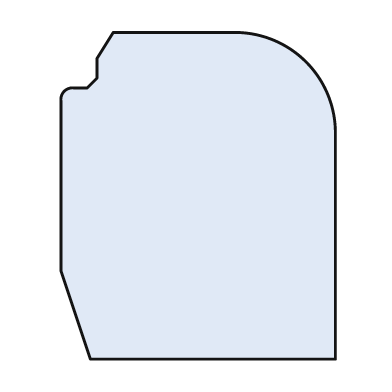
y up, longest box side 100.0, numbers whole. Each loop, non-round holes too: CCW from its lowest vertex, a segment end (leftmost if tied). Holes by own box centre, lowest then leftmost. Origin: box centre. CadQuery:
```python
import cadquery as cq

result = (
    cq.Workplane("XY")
    .moveTo(-33.0, -50.0)
    .lineTo(42.0, -50.0)
    .lineTo(42.0, 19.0)
    .threePointArc((33.0, 41.0), (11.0, 50.0))
    .lineTo(-26.0, 50.0)
    .lineTo(-31.0, 42.0)
    .lineTo(-31.0, 36.0)
    .lineTo(-34.0, 33.0)
    .lineTo(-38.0, 33.0)
    .threePointArc((-41.0, 32.0), (-42.0, 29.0))
    .lineTo(-42.0, -23.0)
    .close()
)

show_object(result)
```